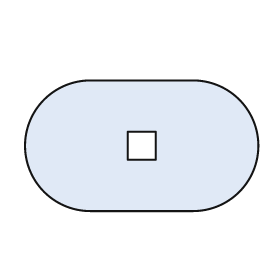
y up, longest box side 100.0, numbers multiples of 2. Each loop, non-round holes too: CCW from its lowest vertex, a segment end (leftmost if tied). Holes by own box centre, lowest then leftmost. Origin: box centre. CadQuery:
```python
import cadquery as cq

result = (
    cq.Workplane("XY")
    .moveTo(-22.0, -28.0)
    .lineTo(22.0, -28.0)
    .threePointArc((50.0, 0.0), (22.0, 28.0))
    .lineTo(-22.0, 28.0)
    .threePointArc((-50.0, 0.0), (-22.0, -28.0))
    .close()
    .moveTo(-6.0, -6.0)
    .lineTo(6.0, -6.0)
    .lineTo(6.0, 6.0)
    .lineTo(-6.0, 6.0)
    .close()
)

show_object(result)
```